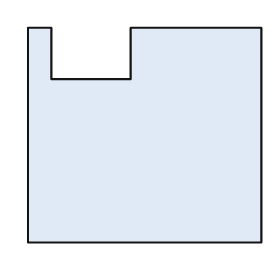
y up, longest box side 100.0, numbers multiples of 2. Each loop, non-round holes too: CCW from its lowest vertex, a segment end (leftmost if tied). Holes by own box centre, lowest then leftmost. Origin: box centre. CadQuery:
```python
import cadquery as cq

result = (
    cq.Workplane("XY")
    .moveTo(-50.0, -46.0)
    .lineTo(50.0, -46.0)
    .lineTo(50.0, 46.0)
    .lineTo(-6.0, 46.0)
    .lineTo(-6.0, 24.0)
    .lineTo(-40.0, 24.0)
    .lineTo(-40.0, 46.0)
    .lineTo(-50.0, 46.0)
    .close()
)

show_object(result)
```